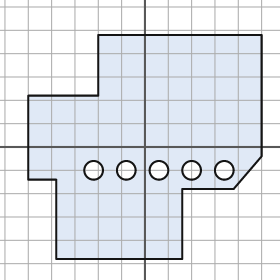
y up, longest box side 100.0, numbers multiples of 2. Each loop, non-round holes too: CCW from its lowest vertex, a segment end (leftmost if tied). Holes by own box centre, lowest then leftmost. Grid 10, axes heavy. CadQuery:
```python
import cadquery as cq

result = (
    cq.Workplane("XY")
    .moveTo(-38.0, -48.0)
    .lineTo(16.0, -48.0)
    .lineTo(16.0, -18.0)
    .lineTo(38.0, -18.0)
    .lineTo(50.0, -4.0)
    .lineTo(50.0, 48.0)
    .lineTo(-20.0, 48.0)
    .lineTo(-20.0, 22.0)
    .lineTo(-50.0, 22.0)
    .lineTo(-50.0, -14.0)
    .lineTo(-38.0, -14.0)
    .close()
    .moveTo(-22.0, -10.0)
    .circle(4.0)
    .moveTo(-8.0, -10.0)
    .circle(4.0)
    .moveTo(6.0, -10.0)
    .circle(4.0)
    .moveTo(20.0, -10.0)
    .circle(4.0)
    .moveTo(34.0, -10.0)
    .circle(4.0)
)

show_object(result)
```